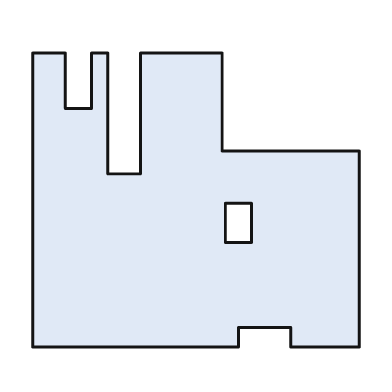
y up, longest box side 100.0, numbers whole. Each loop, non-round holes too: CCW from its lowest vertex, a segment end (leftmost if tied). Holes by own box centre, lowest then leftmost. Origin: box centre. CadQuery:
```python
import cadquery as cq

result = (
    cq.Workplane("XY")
    .moveTo(-50.0, -45.0)
    .lineTo(13.0, -45.0)
    .lineTo(13.0, -39.0)
    .lineTo(29.0, -39.0)
    .lineTo(29.0, -45.0)
    .lineTo(50.0, -45.0)
    .lineTo(50.0, 15.0)
    .lineTo(8.0, 15.0)
    .lineTo(8.0, 45.0)
    .lineTo(-17.0, 45.0)
    .lineTo(-17.0, 8.0)
    .lineTo(-27.0, 8.0)
    .lineTo(-27.0, 45.0)
    .lineTo(-32.0, 45.0)
    .lineTo(-32.0, 28.0)
    .lineTo(-40.0, 28.0)
    .lineTo(-40.0, 45.0)
    .lineTo(-50.0, 45.0)
    .close()
    .moveTo(9.0, -13.0)
    .lineTo(17.0, -13.0)
    .lineTo(17.0, -1.0)
    .lineTo(9.0, -1.0)
    .close()
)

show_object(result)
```